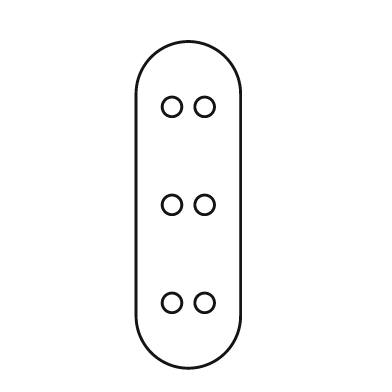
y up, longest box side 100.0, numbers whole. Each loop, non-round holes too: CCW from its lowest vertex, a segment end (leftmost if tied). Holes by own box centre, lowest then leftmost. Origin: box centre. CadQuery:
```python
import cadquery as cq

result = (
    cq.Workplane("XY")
    .moveTo(-16.0, -34.0)
    .threePointArc((0.0, -50.0), (16.0, -34.0))
    .lineTo(16.0, 34.0)
    .threePointArc((0.0, 50.0), (-16.0, 34.0))
    .close()
    .moveTo(-5.0, -30.0)
    .circle(3.0)
    .moveTo(5.0, -30.0)
    .circle(3.0)
    .moveTo(-5.0, 0.0)
    .circle(3.0)
    .moveTo(5.0, 0.0)
    .circle(3.0)
    .moveTo(-5.0, 30.0)
    .circle(3.0)
    .moveTo(5.0, 30.0)
    .circle(3.0)
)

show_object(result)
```